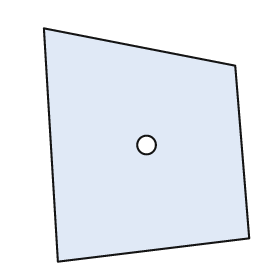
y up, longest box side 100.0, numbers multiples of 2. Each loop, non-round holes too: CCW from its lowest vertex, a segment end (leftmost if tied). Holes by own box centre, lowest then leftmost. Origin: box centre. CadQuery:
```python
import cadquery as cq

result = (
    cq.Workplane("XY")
    .moveTo(-38.0, -50.0)
    .lineTo(44.0, -40.0)
    .lineTo(38.0, 34.0)
    .lineTo(-44.0, 50.0)
    .close()
    .moveTo(0.0, 0.0)
    .circle(4.0)
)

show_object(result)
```